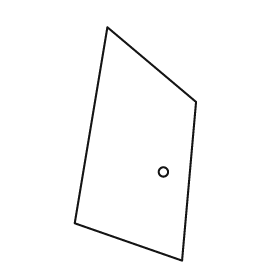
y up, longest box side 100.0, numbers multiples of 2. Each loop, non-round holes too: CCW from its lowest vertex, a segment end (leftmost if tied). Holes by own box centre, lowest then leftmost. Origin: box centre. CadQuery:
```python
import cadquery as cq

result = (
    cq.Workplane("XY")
    .moveTo(20.0, -50.0)
    .lineTo(26.0, 18.0)
    .lineTo(-12.0, 50.0)
    .lineTo(-26.0, -34.0)
    .close()
    .moveTo(12.0, -12.0)
    .circle(2.0)
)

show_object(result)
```